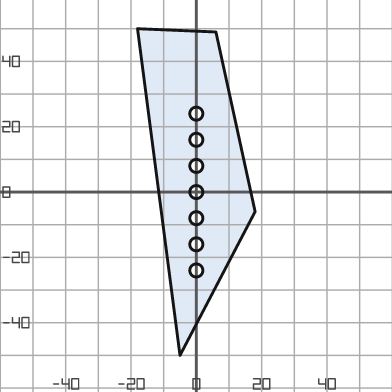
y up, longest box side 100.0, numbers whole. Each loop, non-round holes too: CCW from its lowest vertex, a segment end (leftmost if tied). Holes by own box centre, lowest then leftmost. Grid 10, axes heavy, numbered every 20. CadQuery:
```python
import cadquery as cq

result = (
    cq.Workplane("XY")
    .moveTo(-5.0, -50.0)
    .lineTo(18.0, -6.0)
    .lineTo(6.0, 49.0)
    .lineTo(-18.0, 50.0)
    .close()
    .moveTo(0.0, -24.0)
    .circle(2.0)
    .moveTo(0.0, -16.0)
    .circle(2.0)
    .moveTo(0.0, -8.0)
    .circle(2.0)
    .moveTo(0.0, 0.0)
    .circle(2.0)
    .moveTo(0.0, 8.0)
    .circle(2.0)
    .moveTo(0.0, 16.0)
    .circle(2.0)
    .moveTo(0.0, 24.0)
    .circle(2.0)
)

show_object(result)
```